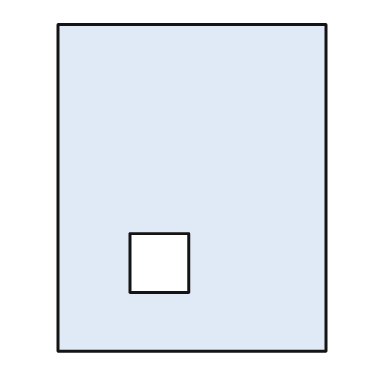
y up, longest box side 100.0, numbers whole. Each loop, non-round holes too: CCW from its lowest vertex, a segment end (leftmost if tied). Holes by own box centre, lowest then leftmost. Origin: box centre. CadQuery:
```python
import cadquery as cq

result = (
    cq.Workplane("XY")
    .moveTo(-41.0, -50.0)
    .lineTo(41.0, -50.0)
    .lineTo(41.0, 50.0)
    .lineTo(-41.0, 50.0)
    .close()
    .moveTo(-19.0, -32.0)
    .lineTo(-1.0, -32.0)
    .lineTo(-1.0, -14.0)
    .lineTo(-19.0, -14.0)
    .close()
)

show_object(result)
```